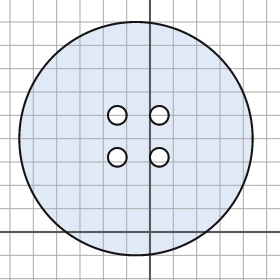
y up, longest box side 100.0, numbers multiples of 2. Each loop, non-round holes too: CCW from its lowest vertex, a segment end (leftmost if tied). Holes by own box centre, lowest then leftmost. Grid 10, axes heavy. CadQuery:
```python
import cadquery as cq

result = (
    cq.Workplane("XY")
    .moveTo(-6.0, 40.0)
    .circle(50.0)
    .moveTo(-14.0, 32.0)
    .circle(4.0)
    .moveTo(4.0, 32.0)
    .circle(4.0)
    .moveTo(-14.0, 50.0)
    .circle(4.0)
    .moveTo(4.0, 50.0)
    .circle(4.0)
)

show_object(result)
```